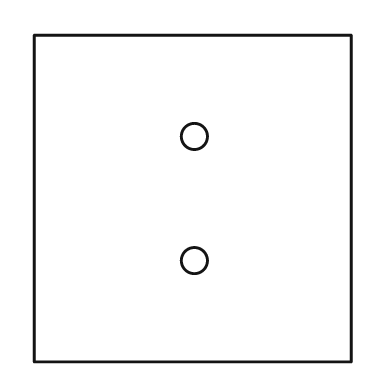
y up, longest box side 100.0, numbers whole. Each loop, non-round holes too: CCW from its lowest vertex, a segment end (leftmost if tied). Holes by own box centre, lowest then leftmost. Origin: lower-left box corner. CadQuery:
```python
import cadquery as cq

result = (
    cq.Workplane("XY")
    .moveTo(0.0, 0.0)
    .lineTo(97.0, 0.0)
    .lineTo(97.0, 100.0)
    .lineTo(0.0, 100.0)
    .close()
    .moveTo(49.0, 31.0)
    .circle(4.0)
    .moveTo(49.0, 69.0)
    .circle(4.0)
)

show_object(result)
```